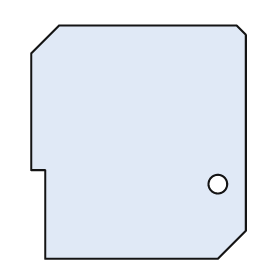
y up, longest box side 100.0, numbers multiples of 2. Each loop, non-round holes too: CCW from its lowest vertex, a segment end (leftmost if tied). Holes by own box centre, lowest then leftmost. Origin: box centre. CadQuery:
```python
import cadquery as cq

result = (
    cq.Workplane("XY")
    .moveTo(-40.0, -50.0)
    .lineTo(34.0, -50.0)
    .lineTo(46.0, -38.0)
    .lineTo(46.0, 46.0)
    .lineTo(42.0, 50.0)
    .lineTo(-34.0, 50.0)
    .lineTo(-46.0, 38.0)
    .lineTo(-46.0, -12.0)
    .lineTo(-40.0, -12.0)
    .close()
    .moveTo(34.0, -18.0)
    .circle(4.0)
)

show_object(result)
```